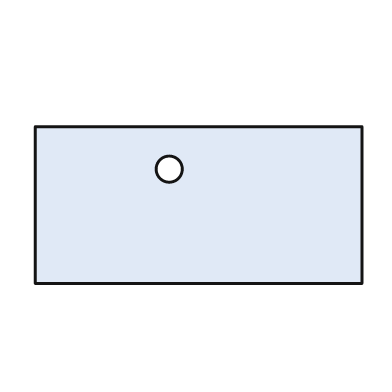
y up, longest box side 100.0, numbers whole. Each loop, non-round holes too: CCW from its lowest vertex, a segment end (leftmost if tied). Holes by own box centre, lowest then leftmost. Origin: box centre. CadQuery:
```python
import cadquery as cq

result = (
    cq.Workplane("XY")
    .moveTo(-50.0, -24.0)
    .lineTo(50.0, -24.0)
    .lineTo(50.0, 24.0)
    .lineTo(-50.0, 24.0)
    .close()
    .moveTo(-9.0, 11.0)
    .circle(4.0)
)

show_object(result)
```